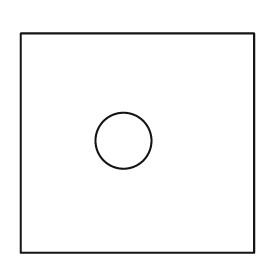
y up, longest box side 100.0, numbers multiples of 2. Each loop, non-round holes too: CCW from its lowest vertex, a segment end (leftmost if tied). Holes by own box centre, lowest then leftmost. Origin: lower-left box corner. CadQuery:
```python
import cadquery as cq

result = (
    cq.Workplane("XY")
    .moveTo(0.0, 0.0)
    .lineTo(100.0, 0.0)
    .lineTo(100.0, 94.0)
    .lineTo(0.0, 94.0)
    .close()
    .moveTo(44.0, 48.0)
    .circle(12.0)
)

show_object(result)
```